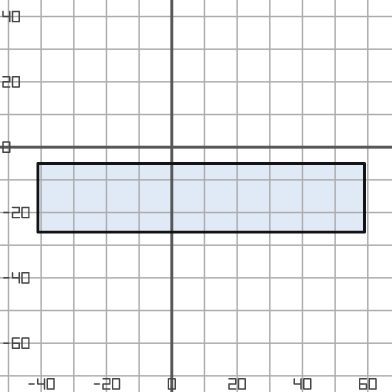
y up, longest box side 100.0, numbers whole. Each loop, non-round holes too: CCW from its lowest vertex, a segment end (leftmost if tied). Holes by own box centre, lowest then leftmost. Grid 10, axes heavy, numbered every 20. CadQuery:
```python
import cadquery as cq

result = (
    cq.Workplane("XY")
    .moveTo(-41.0, -26.0)
    .lineTo(59.0, -26.0)
    .lineTo(59.0, -5.0)
    .lineTo(-41.0, -5.0)
    .close()
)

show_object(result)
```